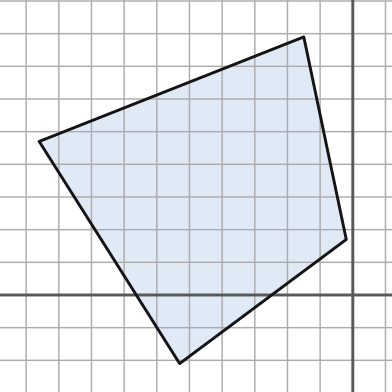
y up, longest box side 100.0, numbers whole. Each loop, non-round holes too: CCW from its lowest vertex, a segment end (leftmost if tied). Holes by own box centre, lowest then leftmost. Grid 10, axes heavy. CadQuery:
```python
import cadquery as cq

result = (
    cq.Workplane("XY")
    .moveTo(-53.0, -21.0)
    .lineTo(-2.0, 17.0)
    .lineTo(-15.0, 79.0)
    .lineTo(-96.0, 47.0)
    .close()
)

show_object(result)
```